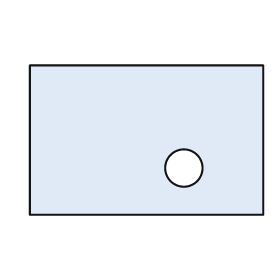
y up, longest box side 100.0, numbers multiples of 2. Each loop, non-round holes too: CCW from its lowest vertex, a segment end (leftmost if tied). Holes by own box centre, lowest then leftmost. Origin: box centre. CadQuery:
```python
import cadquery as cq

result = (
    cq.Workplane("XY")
    .moveTo(-50.0, -32.0)
    .lineTo(50.0, -32.0)
    .lineTo(50.0, 32.0)
    .lineTo(-50.0, 32.0)
    .close()
    .moveTo(16.0, -12.0)
    .circle(8.0)
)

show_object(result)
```